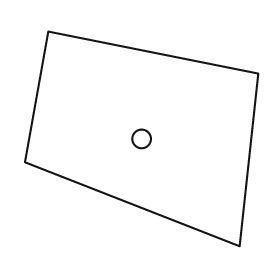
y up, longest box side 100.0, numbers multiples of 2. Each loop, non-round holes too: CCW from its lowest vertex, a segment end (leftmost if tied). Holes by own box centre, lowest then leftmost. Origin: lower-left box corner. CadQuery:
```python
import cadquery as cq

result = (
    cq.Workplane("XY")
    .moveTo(92.0, 0.0)
    .lineTo(100.0, 74.0)
    .lineTo(10.0, 92.0)
    .lineTo(0.0, 36.0)
    .close()
    .moveTo(50.0, 46.0)
    .circle(4.0)
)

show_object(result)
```